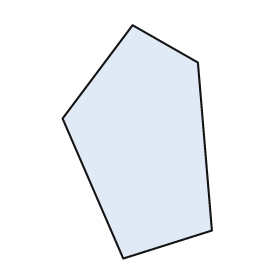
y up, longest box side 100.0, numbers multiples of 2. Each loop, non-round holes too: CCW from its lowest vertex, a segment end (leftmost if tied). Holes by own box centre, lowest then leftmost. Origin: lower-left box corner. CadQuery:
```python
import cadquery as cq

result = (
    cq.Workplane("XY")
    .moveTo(26.0, 0.0)
    .lineTo(64.0, 12.0)
    .lineTo(58.0, 84.0)
    .lineTo(30.0, 100.0)
    .lineTo(0.0, 60.0)
    .close()
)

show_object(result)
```